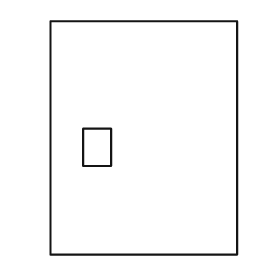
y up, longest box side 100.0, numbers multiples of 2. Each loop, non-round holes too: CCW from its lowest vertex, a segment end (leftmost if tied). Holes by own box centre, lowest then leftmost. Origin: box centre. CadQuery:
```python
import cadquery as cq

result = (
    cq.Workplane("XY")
    .moveTo(-40.0, -50.0)
    .lineTo(40.0, -50.0)
    .lineTo(40.0, 50.0)
    .lineTo(-40.0, 50.0)
    .close()
    .moveTo(-26.0, -12.0)
    .lineTo(-14.0, -12.0)
    .lineTo(-14.0, 4.0)
    .lineTo(-26.0, 4.0)
    .close()
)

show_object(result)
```